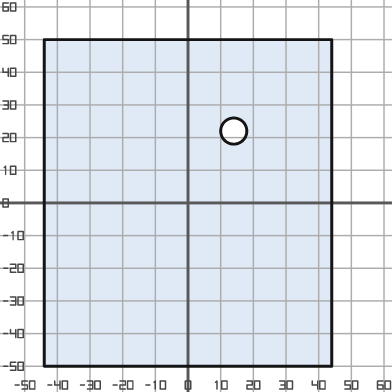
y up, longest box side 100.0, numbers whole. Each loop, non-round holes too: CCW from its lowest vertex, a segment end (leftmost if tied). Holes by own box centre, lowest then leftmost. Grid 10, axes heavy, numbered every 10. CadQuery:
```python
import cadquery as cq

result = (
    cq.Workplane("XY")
    .moveTo(-44.0, -50.0)
    .lineTo(44.0, -50.0)
    .lineTo(44.0, 50.0)
    .lineTo(-44.0, 50.0)
    .close()
    .moveTo(14.0, 22.0)
    .circle(4.0)
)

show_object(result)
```